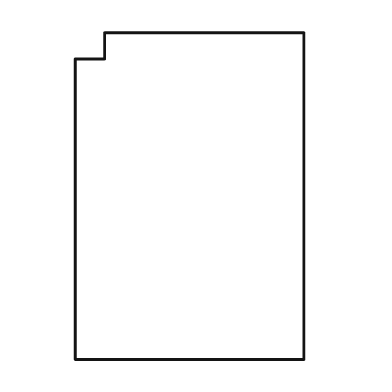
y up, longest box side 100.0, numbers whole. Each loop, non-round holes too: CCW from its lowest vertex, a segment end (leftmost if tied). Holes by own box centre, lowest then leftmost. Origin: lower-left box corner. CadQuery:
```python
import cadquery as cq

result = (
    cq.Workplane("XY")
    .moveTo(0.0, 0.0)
    .lineTo(70.0, 0.0)
    .lineTo(70.0, 100.0)
    .lineTo(9.0, 100.0)
    .lineTo(9.0, 92.0)
    .lineTo(0.0, 92.0)
    .close()
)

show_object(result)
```